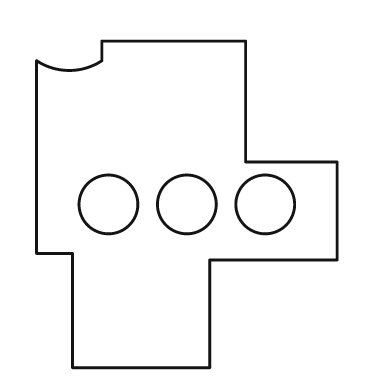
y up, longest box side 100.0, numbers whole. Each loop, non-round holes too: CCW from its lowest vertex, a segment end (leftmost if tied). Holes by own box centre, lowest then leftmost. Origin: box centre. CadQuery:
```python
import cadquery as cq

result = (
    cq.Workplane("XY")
    .moveTo(-35.0, -50.0)
    .lineTo(7.0, -50.0)
    .lineTo(7.0, -17.0)
    .lineTo(46.0, -17.0)
    .lineTo(46.0, 13.0)
    .lineTo(18.0, 13.0)
    .lineTo(18.0, 50.0)
    .lineTo(-26.0, 50.0)
    .lineTo(-26.0, 44.0)
    .threePointArc((-36.0, 41.0), (-46.0, 44.0))
    .lineTo(-46.0, -15.0)
    .lineTo(-35.0, -15.0)
    .close()
    .moveTo(-24.0, 0.0)
    .circle(9.0)
    .moveTo(0.0, 0.0)
    .circle(9.0)
    .moveTo(24.0, 0.0)
    .circle(9.0)
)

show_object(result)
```